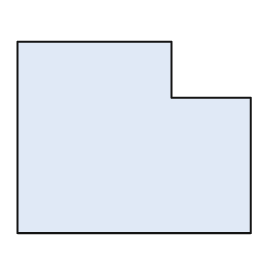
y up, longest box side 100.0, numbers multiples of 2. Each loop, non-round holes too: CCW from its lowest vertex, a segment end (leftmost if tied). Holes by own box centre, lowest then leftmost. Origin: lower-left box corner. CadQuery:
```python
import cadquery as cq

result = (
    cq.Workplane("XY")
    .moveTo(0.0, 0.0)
    .lineTo(100.0, 0.0)
    .lineTo(100.0, 58.0)
    .lineTo(66.0, 58.0)
    .lineTo(66.0, 82.0)
    .lineTo(0.0, 82.0)
    .close()
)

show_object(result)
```